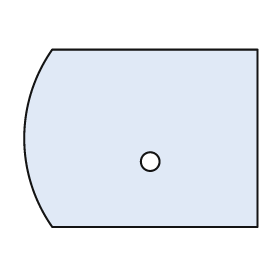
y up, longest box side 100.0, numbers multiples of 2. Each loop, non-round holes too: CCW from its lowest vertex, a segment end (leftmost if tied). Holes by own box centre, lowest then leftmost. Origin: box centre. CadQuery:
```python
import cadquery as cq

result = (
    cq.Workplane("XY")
    .moveTo(-38.0, -38.0)
    .lineTo(50.0, -38.0)
    .lineTo(50.0, 38.0)
    .lineTo(-38.0, 38.0)
    .threePointArc((-50.0, 0.0), (-38.0, -38.0))
    .close()
    .moveTo(4.0, -10.0)
    .circle(4.0)
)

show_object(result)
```